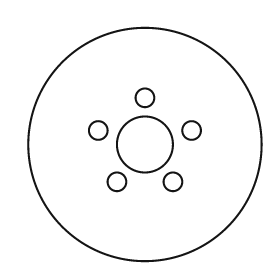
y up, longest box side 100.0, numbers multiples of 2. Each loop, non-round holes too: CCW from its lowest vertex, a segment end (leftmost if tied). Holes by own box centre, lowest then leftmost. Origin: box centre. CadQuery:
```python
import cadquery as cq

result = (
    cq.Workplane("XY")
    .moveTo(0.0, 0.0)
    .circle(50.0)
    .moveTo(-12.0, -16.0)
    .circle(4.0)
    .moveTo(12.0, -16.0)
    .circle(4.0)
    .moveTo(0.0, 0.0)
    .circle(12.0)
    .moveTo(-20.0, 6.0)
    .circle(4.0)
    .moveTo(20.0, 6.0)
    .circle(4.0)
    .moveTo(0.0, 20.0)
    .circle(4.0)
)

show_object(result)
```